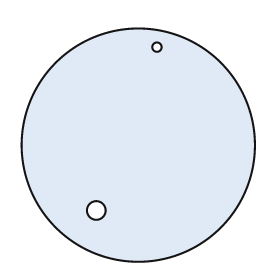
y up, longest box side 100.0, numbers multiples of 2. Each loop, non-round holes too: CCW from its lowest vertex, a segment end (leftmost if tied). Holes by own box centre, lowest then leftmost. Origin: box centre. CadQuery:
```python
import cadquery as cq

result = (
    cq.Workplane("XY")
    .moveTo(0.0, 0.0)
    .circle(50.0)
    .moveTo(-18.0, -28.0)
    .circle(4.0)
    .moveTo(8.0, 42.0)
    .circle(2.0)
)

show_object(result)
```